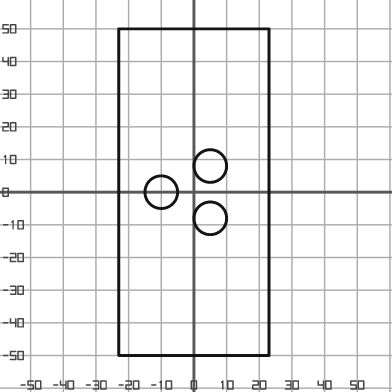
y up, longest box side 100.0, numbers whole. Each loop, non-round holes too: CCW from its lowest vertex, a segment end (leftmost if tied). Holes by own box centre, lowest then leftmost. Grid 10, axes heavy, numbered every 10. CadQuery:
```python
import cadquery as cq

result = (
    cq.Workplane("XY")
    .moveTo(-23.0, -50.0)
    .lineTo(23.0, -50.0)
    .lineTo(23.0, 50.0)
    .lineTo(-23.0, 50.0)
    .close()
    .moveTo(5.0, -8.0)
    .circle(5.0)
    .moveTo(-10.0, 0.0)
    .circle(5.0)
    .moveTo(5.0, 8.0)
    .circle(5.0)
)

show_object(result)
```